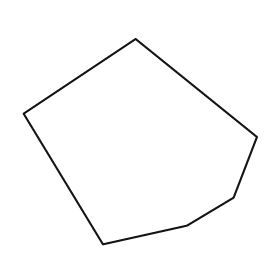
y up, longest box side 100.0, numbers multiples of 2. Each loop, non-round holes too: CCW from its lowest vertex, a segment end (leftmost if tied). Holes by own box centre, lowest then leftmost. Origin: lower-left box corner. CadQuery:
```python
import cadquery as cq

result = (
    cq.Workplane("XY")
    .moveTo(34.0, 0.0)
    .lineTo(70.0, 8.0)
    .lineTo(90.0, 20.0)
    .lineTo(100.0, 46.0)
    .lineTo(48.0, 88.0)
    .lineTo(0.0, 56.0)
    .close()
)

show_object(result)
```